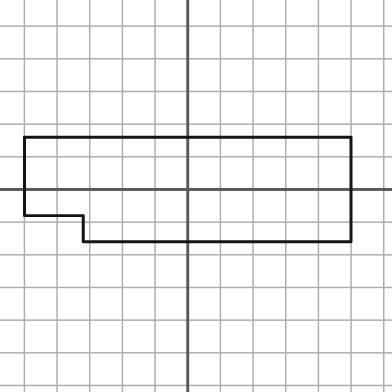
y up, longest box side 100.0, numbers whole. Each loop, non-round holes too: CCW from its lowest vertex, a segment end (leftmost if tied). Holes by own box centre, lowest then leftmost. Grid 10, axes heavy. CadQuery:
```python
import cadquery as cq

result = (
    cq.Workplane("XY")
    .moveTo(-32.0, -16.0)
    .lineTo(50.0, -16.0)
    .lineTo(50.0, 16.0)
    .lineTo(-50.0, 16.0)
    .lineTo(-50.0, -8.0)
    .lineTo(-32.0, -8.0)
    .close()
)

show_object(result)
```